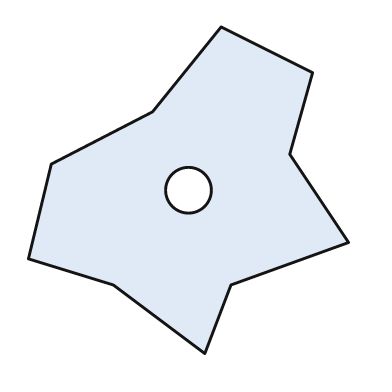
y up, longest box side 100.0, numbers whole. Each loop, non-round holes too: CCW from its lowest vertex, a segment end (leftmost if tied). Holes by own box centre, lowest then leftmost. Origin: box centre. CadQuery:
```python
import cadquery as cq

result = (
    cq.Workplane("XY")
    .moveTo(5.0, -50.0)
    .lineTo(13.0, -29.0)
    .lineTo(49.0, -16.0)
    .lineTo(31.0, 11.0)
    .lineTo(38.0, 36.0)
    .lineTo(10.0, 50.0)
    .lineTo(-11.0, 24.0)
    .lineTo(-42.0, 8.0)
    .lineTo(-49.0, -21.0)
    .lineTo(-23.0, -29.0)
    .close()
    .moveTo(0.0, 0.0)
    .circle(7.0)
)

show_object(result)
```